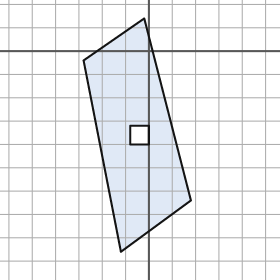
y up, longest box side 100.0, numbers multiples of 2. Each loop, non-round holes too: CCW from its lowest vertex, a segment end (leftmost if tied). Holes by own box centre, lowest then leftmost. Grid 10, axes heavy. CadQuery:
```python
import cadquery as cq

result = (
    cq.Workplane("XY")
    .moveTo(-12.0, -86.0)
    .lineTo(18.0, -64.0)
    .lineTo(-2.0, 14.0)
    .lineTo(-28.0, -4.0)
    .close()
    .moveTo(-8.0, -40.0)
    .lineTo(0.0, -40.0)
    .lineTo(0.0, -32.0)
    .lineTo(-8.0, -32.0)
    .close()
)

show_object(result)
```